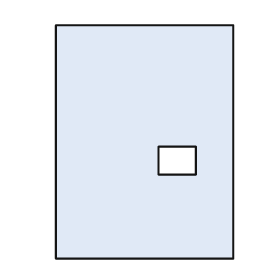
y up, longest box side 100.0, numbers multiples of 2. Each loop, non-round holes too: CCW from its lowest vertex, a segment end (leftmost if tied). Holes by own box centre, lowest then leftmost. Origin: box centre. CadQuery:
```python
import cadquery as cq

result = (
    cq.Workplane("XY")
    .moveTo(-38.0, -50.0)
    .lineTo(38.0, -50.0)
    .lineTo(38.0, 50.0)
    .lineTo(-38.0, 50.0)
    .close()
    .moveTo(6.0, -14.0)
    .lineTo(22.0, -14.0)
    .lineTo(22.0, -2.0)
    .lineTo(6.0, -2.0)
    .close()
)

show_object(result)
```